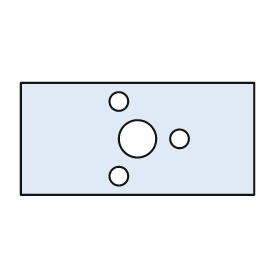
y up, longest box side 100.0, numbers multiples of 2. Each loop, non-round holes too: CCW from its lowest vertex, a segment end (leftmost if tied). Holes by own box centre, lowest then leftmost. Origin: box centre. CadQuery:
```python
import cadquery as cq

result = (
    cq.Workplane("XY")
    .moveTo(-50.0, -24.0)
    .lineTo(50.0, -24.0)
    .lineTo(50.0, 24.0)
    .lineTo(-50.0, 24.0)
    .close()
    .moveTo(-8.0, -16.0)
    .circle(4.0)
    .moveTo(0.0, 0.0)
    .circle(8.0)
    .moveTo(18.0, 0.0)
    .circle(4.0)
    .moveTo(-8.0, 16.0)
    .circle(4.0)
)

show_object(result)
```